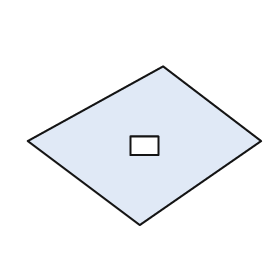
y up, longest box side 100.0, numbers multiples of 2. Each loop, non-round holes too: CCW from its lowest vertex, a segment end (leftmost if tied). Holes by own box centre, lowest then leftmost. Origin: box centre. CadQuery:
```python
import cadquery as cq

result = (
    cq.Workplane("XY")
    .moveTo(-2.0, -34.0)
    .lineTo(50.0, 2.0)
    .lineTo(8.0, 34.0)
    .lineTo(-50.0, 2.0)
    .close()
    .moveTo(-6.0, -4.0)
    .lineTo(6.0, -4.0)
    .lineTo(6.0, 4.0)
    .lineTo(-6.0, 4.0)
    .close()
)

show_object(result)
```